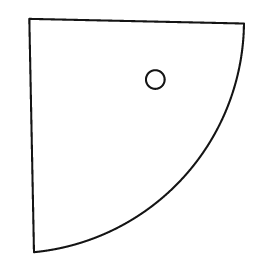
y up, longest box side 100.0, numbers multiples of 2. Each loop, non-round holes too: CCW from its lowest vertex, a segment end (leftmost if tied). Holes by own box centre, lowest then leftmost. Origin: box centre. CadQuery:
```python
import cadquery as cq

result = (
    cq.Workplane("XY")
    .moveTo(-44.0, -50.0)
    .threePointArc((20.0, -18.0), (46.0, 48.0))
    .lineTo(-46.0, 50.0)
    .close()
    .moveTo(8.0, 24.0)
    .circle(4.0)
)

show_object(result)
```